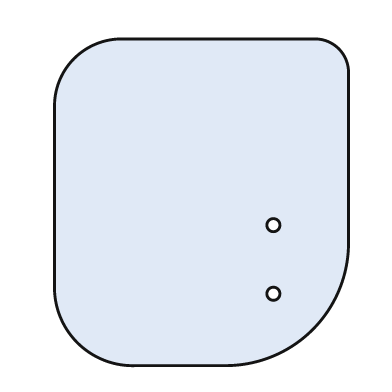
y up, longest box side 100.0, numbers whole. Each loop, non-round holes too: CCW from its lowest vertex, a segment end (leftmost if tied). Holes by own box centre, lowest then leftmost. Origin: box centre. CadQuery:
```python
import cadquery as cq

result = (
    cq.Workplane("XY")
    .moveTo(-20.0, -50.0)
    .lineTo(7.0, -50.0)
    .threePointArc((34.0, -39.0), (45.0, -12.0))
    .lineTo(45.0, 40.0)
    .threePointArc((42.0, 47.0), (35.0, 50.0))
    .lineTo(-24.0, 50.0)
    .threePointArc((-39.0, 44.0), (-45.0, 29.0))
    .lineTo(-45.0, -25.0)
    .threePointArc((-38.0, -43.0), (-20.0, -50.0))
    .close()
    .moveTo(22.0, -28.0)
    .circle(2.0)
    .moveTo(22.0, -7.0)
    .circle(2.0)
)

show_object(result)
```